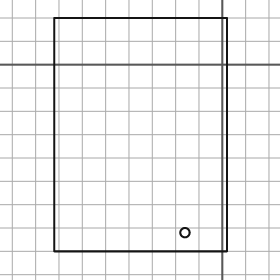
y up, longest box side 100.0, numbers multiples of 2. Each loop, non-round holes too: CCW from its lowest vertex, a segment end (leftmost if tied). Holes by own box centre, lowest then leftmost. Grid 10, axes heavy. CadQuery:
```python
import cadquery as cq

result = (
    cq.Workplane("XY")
    .moveTo(-72.0, -80.0)
    .lineTo(2.0, -80.0)
    .lineTo(2.0, 20.0)
    .lineTo(-72.0, 20.0)
    .close()
    .moveTo(-16.0, -72.0)
    .circle(2.0)
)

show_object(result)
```